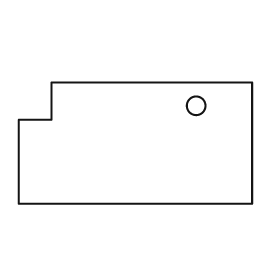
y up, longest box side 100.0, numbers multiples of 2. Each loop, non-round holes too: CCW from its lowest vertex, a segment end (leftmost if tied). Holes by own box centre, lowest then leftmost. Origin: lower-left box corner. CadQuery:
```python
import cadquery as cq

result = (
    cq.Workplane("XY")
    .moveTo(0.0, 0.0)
    .lineTo(100.0, 0.0)
    .lineTo(100.0, 52.0)
    .lineTo(14.0, 52.0)
    .lineTo(14.0, 36.0)
    .lineTo(0.0, 36.0)
    .close()
    .moveTo(76.0, 42.0)
    .circle(4.0)
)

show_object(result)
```